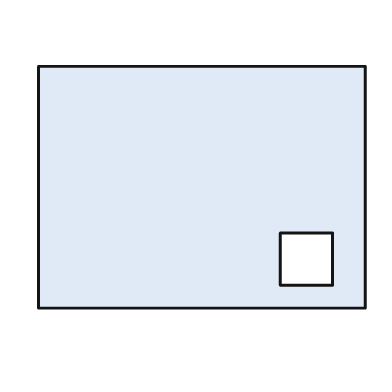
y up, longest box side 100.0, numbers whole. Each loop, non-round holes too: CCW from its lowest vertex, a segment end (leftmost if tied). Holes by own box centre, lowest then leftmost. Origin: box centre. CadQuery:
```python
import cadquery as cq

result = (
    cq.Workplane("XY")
    .moveTo(-50.0, -37.0)
    .lineTo(50.0, -37.0)
    .lineTo(50.0, 37.0)
    .lineTo(-50.0, 37.0)
    .close()
    .moveTo(24.0, -30.0)
    .lineTo(40.0, -30.0)
    .lineTo(40.0, -14.0)
    .lineTo(24.0, -14.0)
    .close()
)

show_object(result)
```